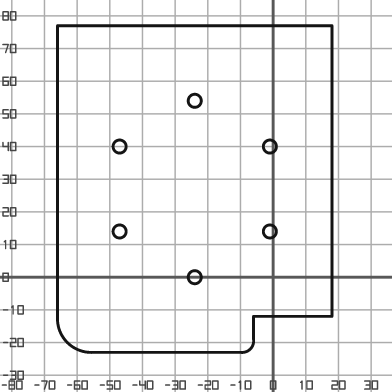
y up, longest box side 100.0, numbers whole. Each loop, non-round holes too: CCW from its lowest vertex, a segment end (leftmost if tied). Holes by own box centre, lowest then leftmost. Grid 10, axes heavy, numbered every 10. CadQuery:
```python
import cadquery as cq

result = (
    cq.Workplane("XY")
    .moveTo(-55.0, -23.0)
    .lineTo(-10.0, -23.0)
    .threePointArc((-7.0, -22.0), (-6.0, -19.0))
    .lineTo(-6.0, -12.0)
    .lineTo(18.0, -12.0)
    .lineTo(18.0, 77.0)
    .lineTo(-66.0, 77.0)
    .lineTo(-66.0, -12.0)
    .threePointArc((-63.0, -20.0), (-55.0, -23.0))
    .close()
    .moveTo(-24.0, 0.0)
    .circle(2.0)
    .moveTo(-47.0, 14.0)
    .circle(2.0)
    .moveTo(-1.0, 14.0)
    .circle(2.0)
    .moveTo(-47.0, 40.0)
    .circle(2.0)
    .moveTo(-1.0, 40.0)
    .circle(2.0)
    .moveTo(-24.0, 54.0)
    .circle(2.0)
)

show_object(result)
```